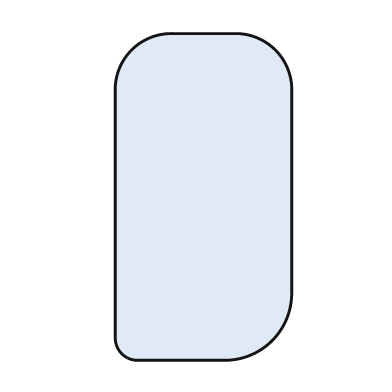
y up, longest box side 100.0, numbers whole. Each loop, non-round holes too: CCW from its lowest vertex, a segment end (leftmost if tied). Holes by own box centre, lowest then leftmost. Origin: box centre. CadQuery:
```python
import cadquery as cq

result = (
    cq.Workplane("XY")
    .moveTo(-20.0, -50.0)
    .lineTo(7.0, -50.0)
    .threePointArc((21.0, -44.0), (27.0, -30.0))
    .lineTo(27.0, 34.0)
    .threePointArc((22.0, 45.0), (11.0, 50.0))
    .lineTo(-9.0, 50.0)
    .threePointArc((-22.0, 45.0), (-27.0, 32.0))
    .lineTo(-27.0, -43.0)
    .threePointArc((-25.0, -48.0), (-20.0, -50.0))
    .close()
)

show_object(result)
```